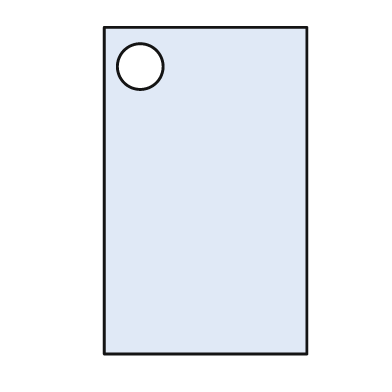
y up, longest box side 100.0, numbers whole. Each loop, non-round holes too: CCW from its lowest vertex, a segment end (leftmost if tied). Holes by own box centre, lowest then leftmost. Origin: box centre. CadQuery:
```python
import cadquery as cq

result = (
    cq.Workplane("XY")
    .moveTo(-31.0, -50.0)
    .lineTo(31.0, -50.0)
    .lineTo(31.0, 50.0)
    .lineTo(-31.0, 50.0)
    .close()
    .moveTo(-20.0, 38.0)
    .circle(7.0)
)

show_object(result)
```